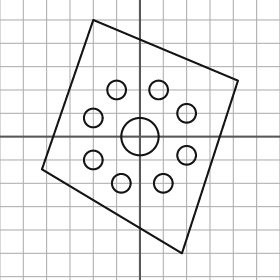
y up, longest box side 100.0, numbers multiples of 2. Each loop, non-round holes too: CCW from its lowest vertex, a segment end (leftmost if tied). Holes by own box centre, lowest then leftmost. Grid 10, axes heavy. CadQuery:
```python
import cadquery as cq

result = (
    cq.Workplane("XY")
    .moveTo(18.0, -50.0)
    .lineTo(42.0, 24.0)
    .lineTo(-20.0, 50.0)
    .lineTo(-42.0, -14.0)
    .close()
    .moveTo(-8.0, -20.0)
    .circle(4.0)
    .moveTo(10.0, -20.0)
    .circle(4.0)
    .moveTo(-20.0, -10.0)
    .circle(4.0)
    .moveTo(20.0, -8.0)
    .circle(4.0)
    .moveTo(0.0, 0.0)
    .circle(8.0)
    .moveTo(-20.0, 8.0)
    .circle(4.0)
    .moveTo(20.0, 10.0)
    .circle(4.0)
    .moveTo(-10.0, 20.0)
    .circle(4.0)
    .moveTo(8.0, 20.0)
    .circle(4.0)
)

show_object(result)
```